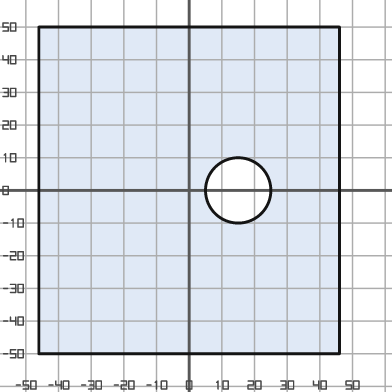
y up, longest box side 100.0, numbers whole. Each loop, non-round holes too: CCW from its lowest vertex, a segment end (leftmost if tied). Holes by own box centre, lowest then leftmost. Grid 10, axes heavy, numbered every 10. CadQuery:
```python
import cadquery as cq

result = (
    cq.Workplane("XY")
    .moveTo(-46.0, -50.0)
    .lineTo(46.0, -50.0)
    .lineTo(46.0, 50.0)
    .lineTo(-46.0, 50.0)
    .close()
    .moveTo(15.0, 0.0)
    .circle(10.0)
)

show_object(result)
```